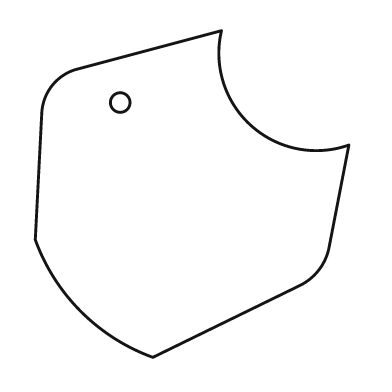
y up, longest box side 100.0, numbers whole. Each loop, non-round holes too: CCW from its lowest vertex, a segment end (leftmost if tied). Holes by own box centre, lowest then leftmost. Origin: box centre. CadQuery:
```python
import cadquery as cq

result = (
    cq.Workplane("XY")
    .moveTo(-12.0, -50.0)
    .lineTo(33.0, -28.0)
    .threePointArc((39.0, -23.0), (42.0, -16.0))
    .lineTo(48.0, 15.0)
    .threePointArc((18.0, 21.0), (9.0, 50.0))
    .lineTo(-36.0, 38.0)
    .threePointArc((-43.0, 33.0), (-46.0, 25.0))
    .lineTo(-48.0, -14.0)
    .threePointArc((-34.0, -36.0), (-12.0, -50.0))
    .close()
    .moveTo(-22.0, 28.0)
    .circle(3.0)
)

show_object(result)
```